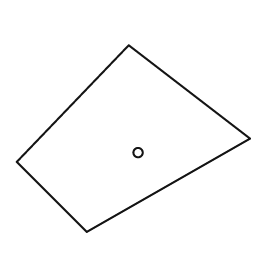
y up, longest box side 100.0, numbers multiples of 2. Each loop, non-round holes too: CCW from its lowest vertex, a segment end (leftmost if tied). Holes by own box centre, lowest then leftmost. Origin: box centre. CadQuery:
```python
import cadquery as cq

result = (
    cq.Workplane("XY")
    .moveTo(-20.0, -40.0)
    .lineTo(50.0, 0.0)
    .lineTo(-2.0, 40.0)
    .lineTo(-50.0, -10.0)
    .close()
    .moveTo(2.0, -6.0)
    .circle(2.0)
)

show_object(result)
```